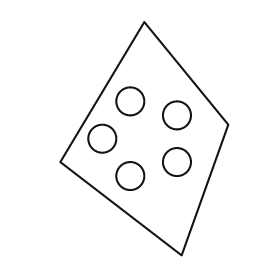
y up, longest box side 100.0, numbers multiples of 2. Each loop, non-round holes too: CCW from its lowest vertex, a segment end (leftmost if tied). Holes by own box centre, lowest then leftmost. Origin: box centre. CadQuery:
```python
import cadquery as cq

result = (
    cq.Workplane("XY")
    .moveTo(16.0, -50.0)
    .lineTo(36.0, 6.0)
    .lineTo(0.0, 50.0)
    .lineTo(-36.0, -10.0)
    .close()
    .moveTo(-6.0, -16.0)
    .circle(6.0)
    .moveTo(14.0, -10.0)
    .circle(6.0)
    .moveTo(-18.0, 0.0)
    .circle(6.0)
    .moveTo(14.0, 10.0)
    .circle(6.0)
    .moveTo(-6.0, 16.0)
    .circle(6.0)
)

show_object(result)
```